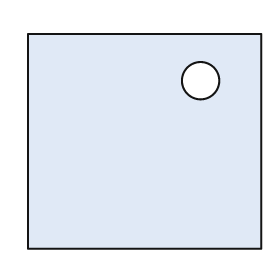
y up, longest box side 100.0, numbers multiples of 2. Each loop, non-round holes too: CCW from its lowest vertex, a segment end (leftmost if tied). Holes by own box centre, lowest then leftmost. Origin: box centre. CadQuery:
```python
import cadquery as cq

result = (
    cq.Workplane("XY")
    .moveTo(-50.0, -46.0)
    .lineTo(50.0, -46.0)
    .lineTo(50.0, 46.0)
    .lineTo(-50.0, 46.0)
    .close()
    .moveTo(24.0, 26.0)
    .circle(8.0)
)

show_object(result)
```